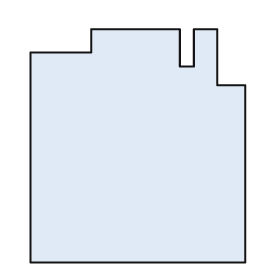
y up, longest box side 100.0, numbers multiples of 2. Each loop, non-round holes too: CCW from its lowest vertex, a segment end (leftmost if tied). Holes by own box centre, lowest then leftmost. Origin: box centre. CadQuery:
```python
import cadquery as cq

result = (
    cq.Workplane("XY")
    .moveTo(-46.0, -50.0)
    .lineTo(46.0, -50.0)
    .lineTo(46.0, 26.0)
    .lineTo(34.0, 26.0)
    .lineTo(34.0, 50.0)
    .lineTo(24.0, 50.0)
    .lineTo(24.0, 34.0)
    .lineTo(18.0, 34.0)
    .lineTo(18.0, 50.0)
    .lineTo(-20.0, 50.0)
    .lineTo(-20.0, 40.0)
    .lineTo(-46.0, 40.0)
    .close()
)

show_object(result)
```